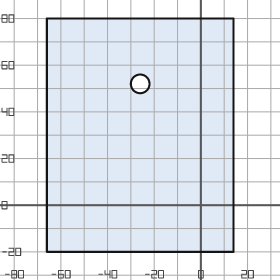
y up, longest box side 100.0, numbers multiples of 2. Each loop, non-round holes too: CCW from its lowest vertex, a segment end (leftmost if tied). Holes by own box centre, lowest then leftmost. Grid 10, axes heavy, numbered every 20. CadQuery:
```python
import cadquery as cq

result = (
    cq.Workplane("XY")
    .moveTo(-66.0, -20.0)
    .lineTo(14.0, -20.0)
    .lineTo(14.0, 80.0)
    .lineTo(-66.0, 80.0)
    .close()
    .moveTo(-26.0, 52.0)
    .circle(4.0)
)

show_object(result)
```